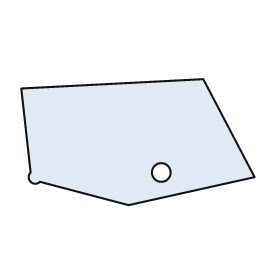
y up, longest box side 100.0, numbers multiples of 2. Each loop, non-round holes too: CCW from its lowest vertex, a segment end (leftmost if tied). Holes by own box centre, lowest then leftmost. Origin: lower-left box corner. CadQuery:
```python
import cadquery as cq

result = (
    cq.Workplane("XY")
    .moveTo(46.0, 0.0)
    .lineTo(100.0, 12.0)
    .lineTo(78.0, 54.0)
    .lineTo(0.0, 50.0)
    .lineTo(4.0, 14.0)
    .threePointArc((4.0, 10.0), (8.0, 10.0))
    .close()
    .moveTo(60.0, 14.0)
    .circle(4.0)
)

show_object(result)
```